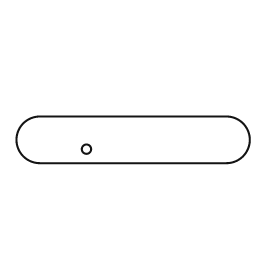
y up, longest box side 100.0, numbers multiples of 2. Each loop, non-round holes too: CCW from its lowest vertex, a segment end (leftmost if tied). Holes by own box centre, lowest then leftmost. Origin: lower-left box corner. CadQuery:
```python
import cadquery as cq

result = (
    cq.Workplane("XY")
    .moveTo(10.0, 0.0)
    .lineTo(90.0, 0.0)
    .threePointArc((100.0, 10.0), (90.0, 20.0))
    .lineTo(10.0, 20.0)
    .threePointArc((0.0, 10.0), (10.0, 0.0))
    .close()
    .moveTo(30.0, 6.0)
    .circle(2.0)
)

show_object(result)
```